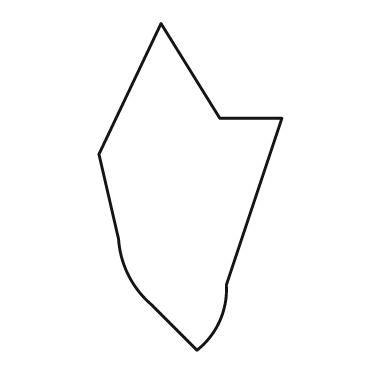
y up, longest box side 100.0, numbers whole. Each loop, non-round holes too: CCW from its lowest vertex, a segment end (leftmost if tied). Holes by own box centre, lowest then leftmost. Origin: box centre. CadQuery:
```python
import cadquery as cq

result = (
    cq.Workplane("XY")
    .moveTo(2.0, -50.0)
    .threePointArc((9.0, -41.0), (11.0, -30.0))
    .lineTo(28.0, 21.0)
    .lineTo(9.0, 21.0)
    .lineTo(-9.0, 50.0)
    .lineTo(-28.0, 10.0)
    .lineTo(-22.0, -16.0)
    .threePointArc((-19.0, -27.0), (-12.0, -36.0))
    .close()
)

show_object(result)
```